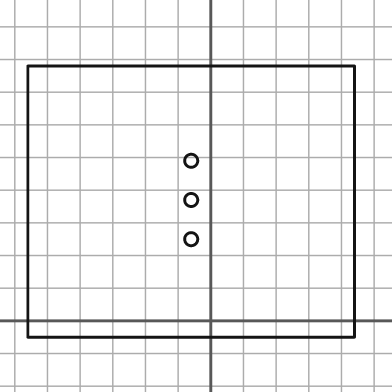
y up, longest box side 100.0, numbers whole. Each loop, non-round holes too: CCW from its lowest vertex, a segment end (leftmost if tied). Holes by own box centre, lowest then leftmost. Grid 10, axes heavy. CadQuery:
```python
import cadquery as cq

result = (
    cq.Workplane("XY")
    .moveTo(-56.0, -5.0)
    .lineTo(44.0, -5.0)
    .lineTo(44.0, 78.0)
    .lineTo(-56.0, 78.0)
    .close()
    .moveTo(-6.0, 25.0)
    .circle(2.0)
    .moveTo(-6.0, 37.0)
    .circle(2.0)
    .moveTo(-6.0, 49.0)
    .circle(2.0)
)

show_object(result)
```